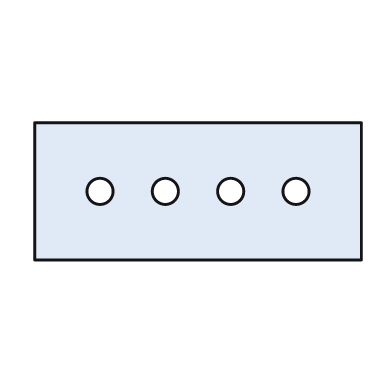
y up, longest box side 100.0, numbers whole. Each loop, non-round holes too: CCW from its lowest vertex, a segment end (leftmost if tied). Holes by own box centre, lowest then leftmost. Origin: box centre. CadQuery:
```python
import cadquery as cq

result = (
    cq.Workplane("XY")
    .moveTo(-50.0, -21.0)
    .lineTo(50.0, -21.0)
    .lineTo(50.0, 21.0)
    .lineTo(-50.0, 21.0)
    .close()
    .moveTo(-30.0, 0.0)
    .circle(4.0)
    .moveTo(-10.0, 0.0)
    .circle(4.0)
    .moveTo(10.0, 0.0)
    .circle(4.0)
    .moveTo(30.0, 0.0)
    .circle(4.0)
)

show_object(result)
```